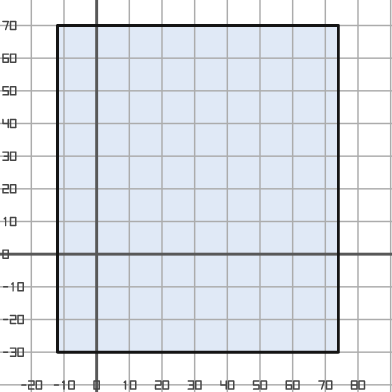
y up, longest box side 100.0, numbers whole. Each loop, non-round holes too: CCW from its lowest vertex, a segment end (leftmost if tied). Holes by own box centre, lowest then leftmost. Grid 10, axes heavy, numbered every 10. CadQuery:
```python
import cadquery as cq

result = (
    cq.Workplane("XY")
    .moveTo(-12.0, -30.0)
    .lineTo(74.0, -30.0)
    .lineTo(74.0, 70.0)
    .lineTo(-12.0, 70.0)
    .close()
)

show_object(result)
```